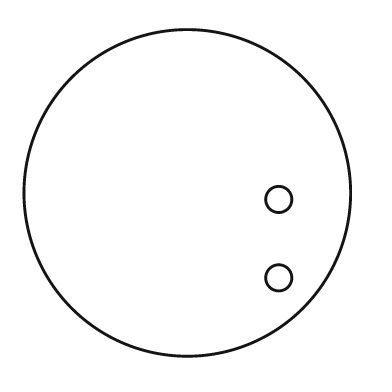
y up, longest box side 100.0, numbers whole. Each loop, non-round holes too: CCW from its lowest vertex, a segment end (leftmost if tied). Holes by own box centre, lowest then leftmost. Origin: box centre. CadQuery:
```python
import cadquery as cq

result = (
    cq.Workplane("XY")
    .moveTo(0.0, 0.0)
    .circle(50.0)
    .moveTo(28.0, -26.0)
    .circle(4.0)
    .moveTo(28.0, -2.0)
    .circle(4.0)
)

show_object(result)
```